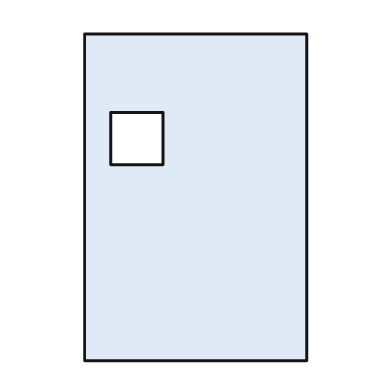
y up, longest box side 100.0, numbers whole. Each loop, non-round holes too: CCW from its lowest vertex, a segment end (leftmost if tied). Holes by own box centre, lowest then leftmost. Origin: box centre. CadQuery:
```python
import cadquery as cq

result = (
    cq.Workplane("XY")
    .moveTo(-34.0, -50.0)
    .lineTo(34.0, -50.0)
    .lineTo(34.0, 50.0)
    .lineTo(-34.0, 50.0)
    .close()
    .moveTo(-26.0, 10.0)
    .lineTo(-10.0, 10.0)
    .lineTo(-10.0, 26.0)
    .lineTo(-26.0, 26.0)
    .close()
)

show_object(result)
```